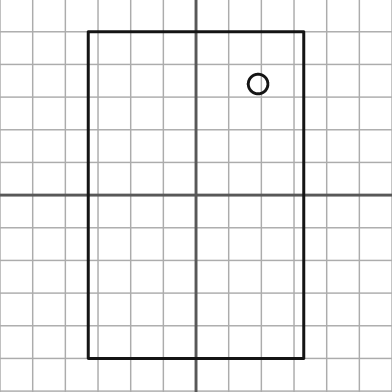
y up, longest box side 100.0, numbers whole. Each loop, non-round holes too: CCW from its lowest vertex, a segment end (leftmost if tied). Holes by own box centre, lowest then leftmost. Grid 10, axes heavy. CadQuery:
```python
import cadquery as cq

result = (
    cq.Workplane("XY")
    .moveTo(-33.0, -50.0)
    .lineTo(33.0, -50.0)
    .lineTo(33.0, 50.0)
    .lineTo(-33.0, 50.0)
    .close()
    .moveTo(19.0, 34.0)
    .circle(3.0)
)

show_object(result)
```